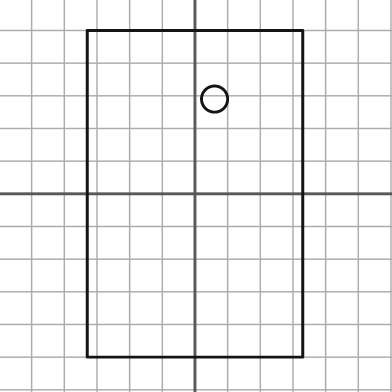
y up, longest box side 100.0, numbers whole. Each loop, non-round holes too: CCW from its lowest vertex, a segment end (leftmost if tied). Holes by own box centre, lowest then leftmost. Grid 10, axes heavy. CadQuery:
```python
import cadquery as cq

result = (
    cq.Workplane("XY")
    .moveTo(-33.0, -50.0)
    .lineTo(33.0, -50.0)
    .lineTo(33.0, 50.0)
    .lineTo(-33.0, 50.0)
    .close()
    .moveTo(6.0, 29.0)
    .circle(4.0)
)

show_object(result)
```